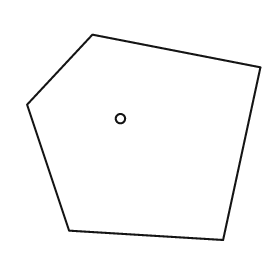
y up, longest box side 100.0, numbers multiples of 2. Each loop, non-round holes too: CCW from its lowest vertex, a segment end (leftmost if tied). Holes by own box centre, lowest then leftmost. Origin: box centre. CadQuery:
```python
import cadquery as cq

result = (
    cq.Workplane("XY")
    .moveTo(34.0, -44.0)
    .lineTo(50.0, 30.0)
    .lineTo(-22.0, 44.0)
    .lineTo(-50.0, 14.0)
    .lineTo(-32.0, -40.0)
    .close()
    .moveTo(-10.0, 8.0)
    .circle(2.0)
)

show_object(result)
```